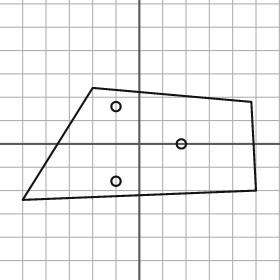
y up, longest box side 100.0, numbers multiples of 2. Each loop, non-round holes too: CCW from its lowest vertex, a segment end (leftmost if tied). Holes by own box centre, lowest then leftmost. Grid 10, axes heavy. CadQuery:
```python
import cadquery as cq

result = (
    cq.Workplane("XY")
    .moveTo(-50.0, -24.0)
    .lineTo(50.0, -20.0)
    .lineTo(48.0, 18.0)
    .lineTo(-20.0, 24.0)
    .close()
    .moveTo(-10.0, -16.0)
    .circle(2.0)
    .moveTo(18.0, 0.0)
    .circle(2.0)
    .moveTo(-10.0, 16.0)
    .circle(2.0)
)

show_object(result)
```